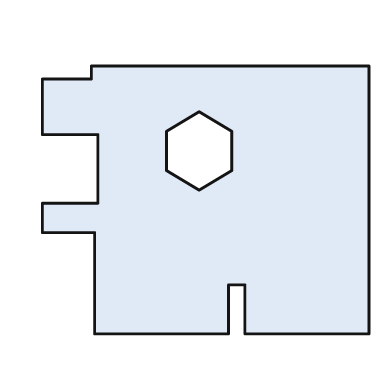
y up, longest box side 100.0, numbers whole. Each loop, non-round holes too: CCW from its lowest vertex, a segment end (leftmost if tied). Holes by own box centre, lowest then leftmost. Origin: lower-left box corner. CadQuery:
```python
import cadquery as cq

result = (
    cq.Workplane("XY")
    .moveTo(16.0, 0.0)
    .lineTo(57.0, 0.0)
    .lineTo(57.0, 15.0)
    .lineTo(62.0, 15.0)
    .lineTo(62.0, 0.0)
    .lineTo(100.0, 0.0)
    .lineTo(100.0, 82.0)
    .lineTo(15.0, 82.0)
    .lineTo(15.0, 78.0)
    .lineTo(0.0, 78.0)
    .lineTo(0.0, 61.0)
    .lineTo(17.0, 61.0)
    .lineTo(17.0, 40.0)
    .lineTo(0.0, 40.0)
    .lineTo(0.0, 31.0)
    .lineTo(16.0, 31.0)
    .close()
    .moveTo(48.0, 44.0)
    .lineTo(58.0, 50.0)
    .lineTo(58.0, 62.0)
    .lineTo(48.0, 68.0)
    .lineTo(38.0, 62.0)
    .lineTo(38.0, 50.0)
    .close()
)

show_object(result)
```